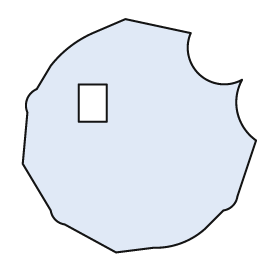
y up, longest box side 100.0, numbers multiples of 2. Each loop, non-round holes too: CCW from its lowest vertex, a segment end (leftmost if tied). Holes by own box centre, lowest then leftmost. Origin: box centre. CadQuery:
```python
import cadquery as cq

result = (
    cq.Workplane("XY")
    .moveTo(-10.0, -50.0)
    .lineTo(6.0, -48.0)
    .threePointArc((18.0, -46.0), (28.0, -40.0))
    .lineTo(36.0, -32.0)
    .threePointArc((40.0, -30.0), (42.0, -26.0))
    .lineTo(50.0, -2.0)
    .threePointArc((42.0, 10.0), (44.0, 24.0))
    .threePointArc((26.0, 26.0), (22.0, 44.0))
    .lineTo(-6.0, 50.0)
    .lineTo(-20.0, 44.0)
    .threePointArc((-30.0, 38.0), (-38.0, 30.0))
    .lineTo(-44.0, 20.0)
    .threePointArc((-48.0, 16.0), (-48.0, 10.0))
    .lineTo(-50.0, -12.0)
    .lineTo(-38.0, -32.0)
    .threePointArc((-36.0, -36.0), (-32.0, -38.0))
    .close()
    .moveTo(-26.0, 6.0)
    .lineTo(-14.0, 6.0)
    .lineTo(-14.0, 22.0)
    .lineTo(-26.0, 22.0)
    .close()
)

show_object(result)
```